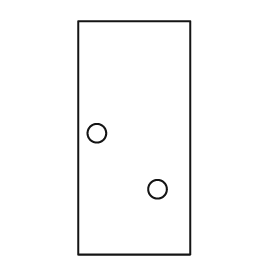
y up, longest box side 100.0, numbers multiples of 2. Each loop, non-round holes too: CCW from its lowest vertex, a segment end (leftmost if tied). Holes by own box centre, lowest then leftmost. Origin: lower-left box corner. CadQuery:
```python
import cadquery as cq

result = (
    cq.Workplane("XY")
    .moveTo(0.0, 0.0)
    .lineTo(48.0, 0.0)
    .lineTo(48.0, 100.0)
    .lineTo(0.0, 100.0)
    .close()
    .moveTo(34.0, 28.0)
    .circle(4.0)
    .moveTo(8.0, 52.0)
    .circle(4.0)
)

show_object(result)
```